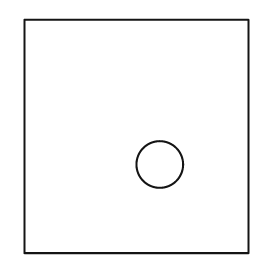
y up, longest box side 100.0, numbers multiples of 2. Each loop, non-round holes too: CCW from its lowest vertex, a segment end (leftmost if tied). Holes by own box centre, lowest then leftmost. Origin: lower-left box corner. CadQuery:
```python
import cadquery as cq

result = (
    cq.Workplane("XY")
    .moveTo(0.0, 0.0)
    .lineTo(96.0, 0.0)
    .lineTo(96.0, 100.0)
    .lineTo(0.0, 100.0)
    .close()
    .moveTo(58.0, 38.0)
    .circle(10.0)
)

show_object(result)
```